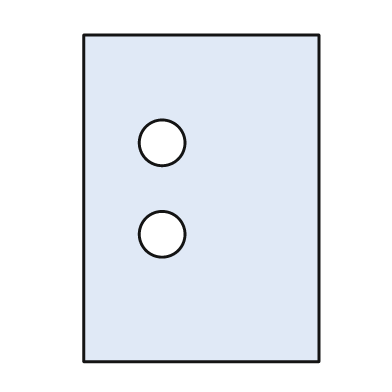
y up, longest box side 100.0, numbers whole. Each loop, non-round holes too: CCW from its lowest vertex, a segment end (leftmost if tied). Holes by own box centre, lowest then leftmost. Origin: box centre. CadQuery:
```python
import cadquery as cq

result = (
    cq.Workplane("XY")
    .moveTo(-36.0, -50.0)
    .lineTo(36.0, -50.0)
    .lineTo(36.0, 50.0)
    .lineTo(-36.0, 50.0)
    .close()
    .moveTo(-12.0, -11.0)
    .circle(7.0)
    .moveTo(-12.0, 17.0)
    .circle(7.0)
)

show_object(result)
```